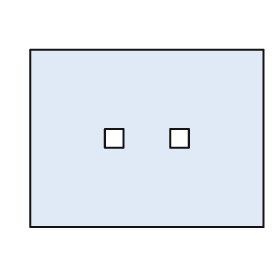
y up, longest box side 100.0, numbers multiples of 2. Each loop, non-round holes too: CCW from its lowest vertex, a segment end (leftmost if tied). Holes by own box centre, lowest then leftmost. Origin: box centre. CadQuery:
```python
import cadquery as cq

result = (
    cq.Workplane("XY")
    .moveTo(-50.0, -38.0)
    .lineTo(50.0, -38.0)
    .lineTo(50.0, 38.0)
    .lineTo(-50.0, 38.0)
    .close()
    .moveTo(-18.0, -4.0)
    .lineTo(-10.0, -4.0)
    .lineTo(-10.0, 4.0)
    .lineTo(-18.0, 4.0)
    .close()
    .moveTo(10.0, -4.0)
    .lineTo(18.0, -4.0)
    .lineTo(18.0, 4.0)
    .lineTo(10.0, 4.0)
    .close()
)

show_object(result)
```